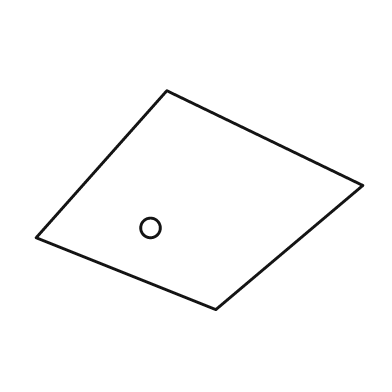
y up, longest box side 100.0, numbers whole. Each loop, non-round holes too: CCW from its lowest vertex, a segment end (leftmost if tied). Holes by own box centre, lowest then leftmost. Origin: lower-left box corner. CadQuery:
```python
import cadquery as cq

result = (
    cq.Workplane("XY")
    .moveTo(55.0, 0.0)
    .lineTo(100.0, 38.0)
    .lineTo(40.0, 67.0)
    .lineTo(0.0, 22.0)
    .close()
    .moveTo(35.0, 25.0)
    .circle(3.0)
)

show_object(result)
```